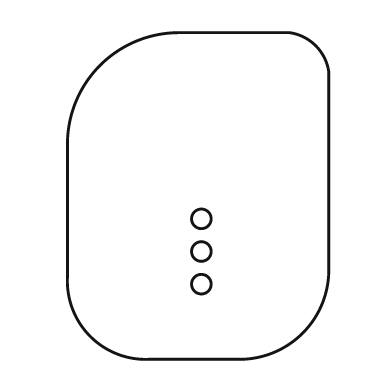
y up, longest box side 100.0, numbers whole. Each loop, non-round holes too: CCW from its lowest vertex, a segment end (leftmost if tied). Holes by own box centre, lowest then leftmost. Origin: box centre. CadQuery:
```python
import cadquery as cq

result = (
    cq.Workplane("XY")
    .moveTo(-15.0, -50.0)
    .lineTo(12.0, -50.0)
    .threePointArc((32.0, -42.0), (40.0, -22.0))
    .lineTo(40.0, 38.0)
    .threePointArc((36.0, 46.0), (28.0, 50.0))
    .lineTo(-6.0, 50.0)
    .threePointArc((-30.0, 40.0), (-40.0, 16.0))
    .lineTo(-40.0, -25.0)
    .threePointArc((-33.0, -43.0), (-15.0, -50.0))
    .close()
    .moveTo(1.0, -27.0)
    .circle(3.0)
    .moveTo(1.0, -17.0)
    .circle(3.0)
    .moveTo(1.0, -7.0)
    .circle(3.0)
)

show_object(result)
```